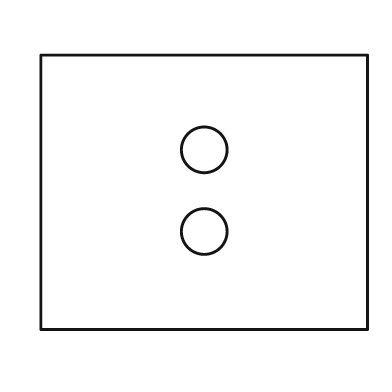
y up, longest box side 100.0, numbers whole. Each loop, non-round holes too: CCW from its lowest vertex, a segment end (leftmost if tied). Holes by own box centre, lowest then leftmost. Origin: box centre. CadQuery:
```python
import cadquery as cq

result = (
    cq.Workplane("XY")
    .moveTo(-50.0, -42.0)
    .lineTo(50.0, -42.0)
    .lineTo(50.0, 42.0)
    .lineTo(-50.0, 42.0)
    .close()
    .moveTo(0.0, -12.0)
    .circle(7.0)
    .moveTo(0.0, 13.0)
    .circle(7.0)
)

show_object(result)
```